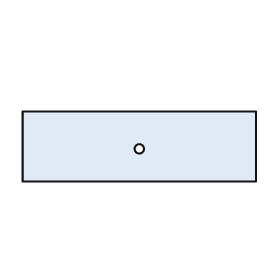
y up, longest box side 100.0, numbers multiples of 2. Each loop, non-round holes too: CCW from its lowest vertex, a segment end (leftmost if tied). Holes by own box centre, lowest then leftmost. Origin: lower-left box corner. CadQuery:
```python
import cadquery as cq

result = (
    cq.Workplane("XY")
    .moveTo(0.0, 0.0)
    .lineTo(100.0, 0.0)
    .lineTo(100.0, 30.0)
    .lineTo(0.0, 30.0)
    .close()
    .moveTo(50.0, 14.0)
    .circle(2.0)
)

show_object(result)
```